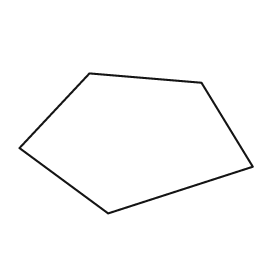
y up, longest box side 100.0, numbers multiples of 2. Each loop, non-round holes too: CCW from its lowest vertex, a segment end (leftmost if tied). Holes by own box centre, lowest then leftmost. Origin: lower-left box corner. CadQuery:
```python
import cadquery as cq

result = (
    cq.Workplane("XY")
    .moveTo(38.0, 0.0)
    .lineTo(100.0, 20.0)
    .lineTo(78.0, 56.0)
    .lineTo(30.0, 60.0)
    .lineTo(0.0, 28.0)
    .close()
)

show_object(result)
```